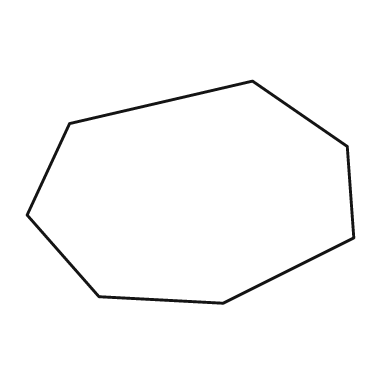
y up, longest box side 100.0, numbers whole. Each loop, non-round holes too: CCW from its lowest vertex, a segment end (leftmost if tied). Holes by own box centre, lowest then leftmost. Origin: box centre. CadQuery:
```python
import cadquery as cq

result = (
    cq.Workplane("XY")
    .moveTo(10.0, -34.0)
    .lineTo(50.0, -14.0)
    .lineTo(48.0, 14.0)
    .lineTo(19.0, 34.0)
    .lineTo(-37.0, 21.0)
    .lineTo(-50.0, -7.0)
    .lineTo(-28.0, -32.0)
    .close()
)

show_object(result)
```